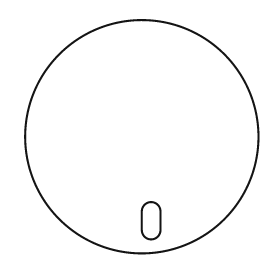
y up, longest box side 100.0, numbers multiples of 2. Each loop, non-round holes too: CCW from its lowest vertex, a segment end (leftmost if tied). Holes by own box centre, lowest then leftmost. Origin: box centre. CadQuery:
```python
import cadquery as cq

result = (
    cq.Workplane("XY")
    .moveTo(0.0, 0.0)
    .circle(50.0)
    .moveTo(0.0, -40.0)
    .threePointArc((4.0, -44.0), (8.0, -40.0))
    .lineTo(8.0, -32.0)
    .threePointArc((4.0, -28.0), (0.0, -32.0))
    .close()
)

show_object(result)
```